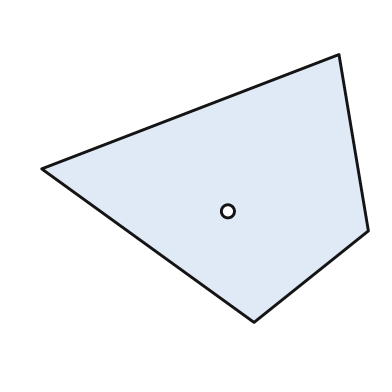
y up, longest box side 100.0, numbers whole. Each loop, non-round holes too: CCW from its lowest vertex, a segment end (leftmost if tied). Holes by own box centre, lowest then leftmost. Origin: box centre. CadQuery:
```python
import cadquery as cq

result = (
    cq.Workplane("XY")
    .moveTo(15.0, -41.0)
    .lineTo(50.0, -13.0)
    .lineTo(41.0, 41.0)
    .lineTo(-50.0, 6.0)
    .close()
    .moveTo(7.0, -7.0)
    .circle(2.0)
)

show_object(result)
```